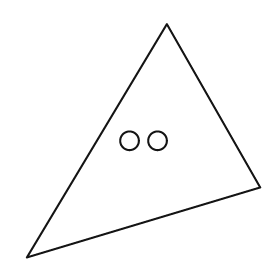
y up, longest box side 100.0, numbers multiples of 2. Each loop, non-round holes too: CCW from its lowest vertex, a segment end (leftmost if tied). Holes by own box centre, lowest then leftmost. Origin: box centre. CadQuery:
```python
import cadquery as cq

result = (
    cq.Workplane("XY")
    .moveTo(-50.0, -50.0)
    .lineTo(50.0, -20.0)
    .lineTo(10.0, 50.0)
    .close()
    .moveTo(-6.0, 0.0)
    .circle(4.0)
    .moveTo(6.0, 0.0)
    .circle(4.0)
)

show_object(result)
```